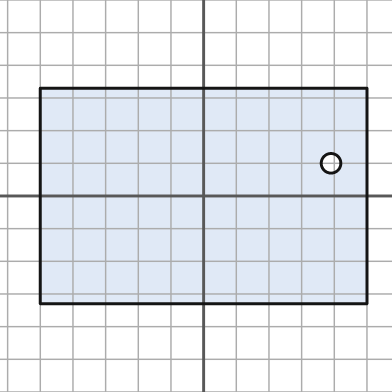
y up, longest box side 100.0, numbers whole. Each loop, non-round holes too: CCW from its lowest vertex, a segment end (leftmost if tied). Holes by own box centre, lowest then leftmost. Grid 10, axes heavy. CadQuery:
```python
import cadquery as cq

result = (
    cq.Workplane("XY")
    .moveTo(-50.0, -33.0)
    .lineTo(50.0, -33.0)
    .lineTo(50.0, 33.0)
    .lineTo(-50.0, 33.0)
    .close()
    .moveTo(39.0, 10.0)
    .circle(3.0)
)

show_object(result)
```